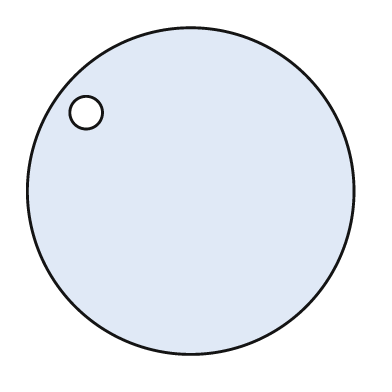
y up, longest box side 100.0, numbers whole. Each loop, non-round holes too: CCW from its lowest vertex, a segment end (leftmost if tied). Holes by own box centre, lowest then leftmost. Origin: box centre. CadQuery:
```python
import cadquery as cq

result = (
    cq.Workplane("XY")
    .moveTo(0.0, 0.0)
    .circle(50.0)
    .moveTo(-32.0, 24.0)
    .circle(5.0)
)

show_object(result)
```